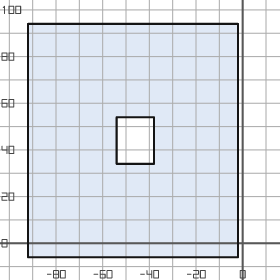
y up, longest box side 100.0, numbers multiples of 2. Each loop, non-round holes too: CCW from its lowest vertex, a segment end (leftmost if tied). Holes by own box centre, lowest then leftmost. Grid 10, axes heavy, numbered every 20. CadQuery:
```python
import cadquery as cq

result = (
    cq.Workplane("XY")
    .moveTo(-92.0, -6.0)
    .lineTo(-2.0, -6.0)
    .lineTo(-2.0, 94.0)
    .lineTo(-92.0, 94.0)
    .close()
    .moveTo(-54.0, 34.0)
    .lineTo(-38.0, 34.0)
    .lineTo(-38.0, 54.0)
    .lineTo(-54.0, 54.0)
    .close()
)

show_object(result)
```